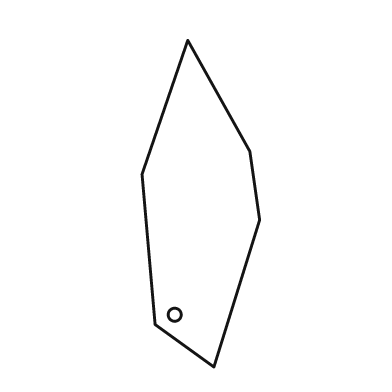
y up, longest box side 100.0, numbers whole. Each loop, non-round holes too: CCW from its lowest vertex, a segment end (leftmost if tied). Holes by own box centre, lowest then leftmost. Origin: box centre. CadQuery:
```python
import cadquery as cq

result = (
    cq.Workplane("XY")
    .moveTo(4.0, -50.0)
    .lineTo(18.0, -5.0)
    .lineTo(15.0, 16.0)
    .lineTo(-4.0, 50.0)
    .lineTo(-18.0, 9.0)
    .lineTo(-14.0, -37.0)
    .close()
    .moveTo(-8.0, -34.0)
    .circle(2.0)
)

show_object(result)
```